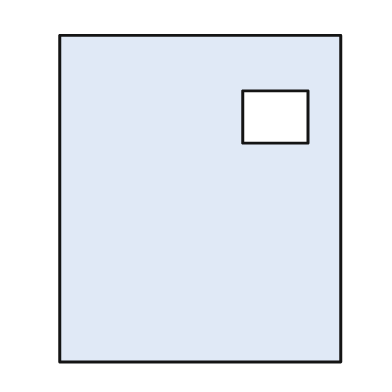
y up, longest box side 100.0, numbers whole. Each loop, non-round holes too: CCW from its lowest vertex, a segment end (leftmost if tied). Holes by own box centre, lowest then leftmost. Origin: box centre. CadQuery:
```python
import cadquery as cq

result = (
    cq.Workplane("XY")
    .moveTo(-43.0, -50.0)
    .lineTo(43.0, -50.0)
    .lineTo(43.0, 50.0)
    .lineTo(-43.0, 50.0)
    .close()
    .moveTo(13.0, 17.0)
    .lineTo(33.0, 17.0)
    .lineTo(33.0, 33.0)
    .lineTo(13.0, 33.0)
    .close()
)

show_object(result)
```